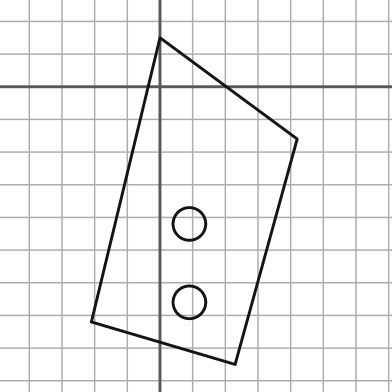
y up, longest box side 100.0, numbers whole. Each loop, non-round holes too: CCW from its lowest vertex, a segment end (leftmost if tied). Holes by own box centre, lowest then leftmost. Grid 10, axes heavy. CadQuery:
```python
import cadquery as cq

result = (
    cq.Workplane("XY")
    .moveTo(23.0, -85.0)
    .lineTo(42.0, -16.0)
    .lineTo(0.0, 15.0)
    .lineTo(-21.0, -72.0)
    .close()
    .moveTo(9.0, -66.0)
    .circle(5.0)
    .moveTo(9.0, -42.0)
    .circle(5.0)
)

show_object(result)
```